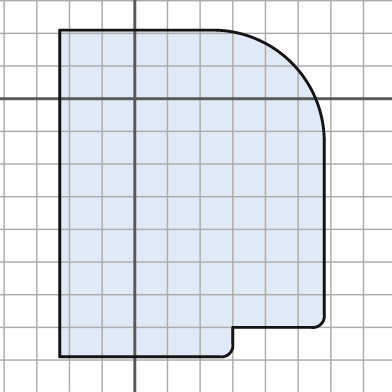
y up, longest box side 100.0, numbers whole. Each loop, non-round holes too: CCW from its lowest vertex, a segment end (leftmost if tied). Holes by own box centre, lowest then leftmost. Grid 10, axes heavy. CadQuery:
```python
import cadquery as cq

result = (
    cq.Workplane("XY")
    .moveTo(-23.0, -79.0)
    .lineTo(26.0, -79.0)
    .threePointArc((29.0, -78.0), (30.0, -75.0))
    .lineTo(30.0, -70.0)
    .lineTo(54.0, -70.0)
    .threePointArc((57.0, -69.0), (58.0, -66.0))
    .lineTo(58.0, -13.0)
    .threePointArc((48.0, 11.0), (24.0, 21.0))
    .lineTo(-23.0, 21.0)
    .close()
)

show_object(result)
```